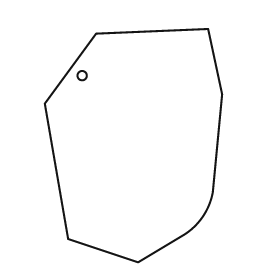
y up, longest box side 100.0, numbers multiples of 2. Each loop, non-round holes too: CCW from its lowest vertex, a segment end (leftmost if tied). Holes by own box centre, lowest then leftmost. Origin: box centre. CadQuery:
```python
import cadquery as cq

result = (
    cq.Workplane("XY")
    .moveTo(2.0, -50.0)
    .lineTo(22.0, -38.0)
    .threePointArc((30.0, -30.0), (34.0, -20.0))
    .lineTo(38.0, 22.0)
    .lineTo(32.0, 50.0)
    .lineTo(-16.0, 48.0)
    .lineTo(-38.0, 18.0)
    .lineTo(-28.0, -40.0)
    .close()
    .moveTo(-22.0, 30.0)
    .circle(2.0)
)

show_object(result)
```